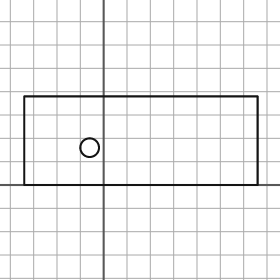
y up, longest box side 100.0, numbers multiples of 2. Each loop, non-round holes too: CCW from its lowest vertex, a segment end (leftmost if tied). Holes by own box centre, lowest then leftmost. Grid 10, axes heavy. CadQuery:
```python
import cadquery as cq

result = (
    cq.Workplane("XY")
    .moveTo(-34.0, 0.0)
    .lineTo(66.0, 0.0)
    .lineTo(66.0, 38.0)
    .lineTo(-34.0, 38.0)
    .close()
    .moveTo(-6.0, 16.0)
    .circle(4.0)
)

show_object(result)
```